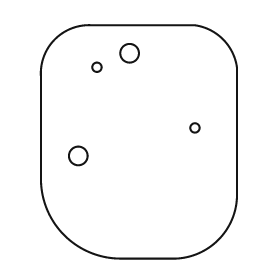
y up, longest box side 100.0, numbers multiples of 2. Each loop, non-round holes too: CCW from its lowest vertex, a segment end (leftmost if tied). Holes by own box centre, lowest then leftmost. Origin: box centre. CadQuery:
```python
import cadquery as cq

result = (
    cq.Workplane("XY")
    .moveTo(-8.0, -50.0)
    .lineTo(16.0, -50.0)
    .threePointArc((34.0, -42.0), (42.0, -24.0))
    .lineTo(42.0, 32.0)
    .threePointArc((36.0, 44.0), (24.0, 50.0))
    .lineTo(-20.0, 50.0)
    .threePointArc((-36.0, 44.0), (-42.0, 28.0))
    .lineTo(-42.0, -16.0)
    .threePointArc((-32.0, -40.0), (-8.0, -50.0))
    .close()
    .moveTo(-26.0, -6.0)
    .circle(4.0)
    .moveTo(24.0, 6.0)
    .circle(2.0)
    .moveTo(-18.0, 32.0)
    .circle(2.0)
    .moveTo(-4.0, 38.0)
    .circle(4.0)
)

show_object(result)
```